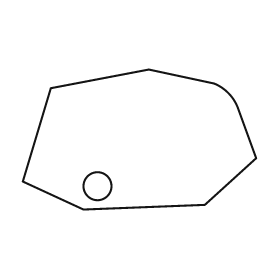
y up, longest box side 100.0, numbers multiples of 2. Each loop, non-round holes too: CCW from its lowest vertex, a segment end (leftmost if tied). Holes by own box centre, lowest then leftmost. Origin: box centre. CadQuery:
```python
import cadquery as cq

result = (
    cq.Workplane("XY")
    .moveTo(-24.0, -30.0)
    .lineTo(28.0, -28.0)
    .lineTo(50.0, -8.0)
    .lineTo(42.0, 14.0)
    .threePointArc((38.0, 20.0), (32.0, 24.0))
    .lineTo(4.0, 30.0)
    .lineTo(-38.0, 22.0)
    .lineTo(-50.0, -18.0)
    .close()
    .moveTo(-18.0, -20.0)
    .circle(6.0)
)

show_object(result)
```